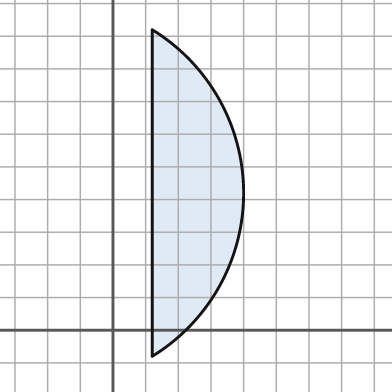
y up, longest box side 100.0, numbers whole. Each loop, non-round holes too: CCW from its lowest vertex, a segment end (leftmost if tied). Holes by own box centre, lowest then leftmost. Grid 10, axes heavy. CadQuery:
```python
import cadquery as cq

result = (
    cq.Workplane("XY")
    .moveTo(12.0, -8.0)
    .threePointArc((40.0, 42.0), (12.0, 92.0))
    .close()
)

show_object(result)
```